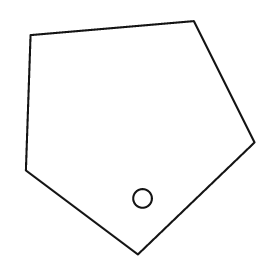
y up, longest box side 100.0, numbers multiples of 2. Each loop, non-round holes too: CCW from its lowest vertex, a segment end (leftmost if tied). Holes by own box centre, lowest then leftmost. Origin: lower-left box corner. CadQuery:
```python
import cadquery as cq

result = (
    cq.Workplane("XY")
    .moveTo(48.0, 0.0)
    .lineTo(98.0, 48.0)
    .lineTo(72.0, 100.0)
    .lineTo(2.0, 94.0)
    .lineTo(0.0, 36.0)
    .close()
    .moveTo(50.0, 24.0)
    .circle(4.0)
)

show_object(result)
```